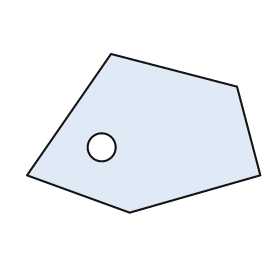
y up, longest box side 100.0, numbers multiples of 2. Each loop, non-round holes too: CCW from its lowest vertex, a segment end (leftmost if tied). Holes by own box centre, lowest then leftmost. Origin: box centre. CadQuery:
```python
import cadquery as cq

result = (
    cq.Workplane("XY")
    .moveTo(-6.0, -34.0)
    .lineTo(50.0, -18.0)
    .lineTo(40.0, 20.0)
    .lineTo(-14.0, 34.0)
    .lineTo(-50.0, -18.0)
    .close()
    .moveTo(-18.0, -6.0)
    .circle(6.0)
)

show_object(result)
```